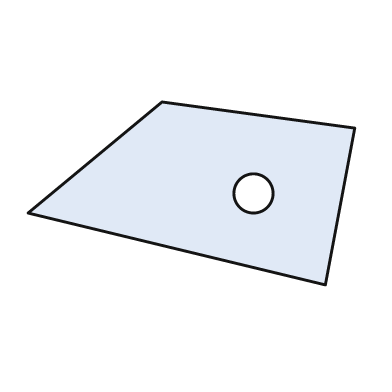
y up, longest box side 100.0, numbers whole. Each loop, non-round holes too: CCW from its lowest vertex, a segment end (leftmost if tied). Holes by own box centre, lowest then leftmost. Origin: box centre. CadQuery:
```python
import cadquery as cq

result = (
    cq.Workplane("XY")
    .moveTo(41.0, -28.0)
    .lineTo(50.0, 20.0)
    .lineTo(-9.0, 28.0)
    .lineTo(-50.0, -6.0)
    .close()
    .moveTo(19.0, 0.0)
    .circle(6.0)
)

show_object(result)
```